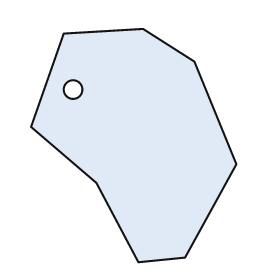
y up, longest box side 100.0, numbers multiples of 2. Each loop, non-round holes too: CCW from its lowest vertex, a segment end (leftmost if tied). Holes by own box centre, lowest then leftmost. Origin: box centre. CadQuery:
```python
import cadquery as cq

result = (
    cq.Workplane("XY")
    .moveTo(2.0, -50.0)
    .lineTo(22.0, -48.0)
    .lineTo(44.0, -8.0)
    .lineTo(26.0, 36.0)
    .lineTo(4.0, 50.0)
    .lineTo(-30.0, 48.0)
    .lineTo(-44.0, 8.0)
    .lineTo(-16.0, -16.0)
    .close()
    .moveTo(-26.0, 24.0)
    .circle(4.0)
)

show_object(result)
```